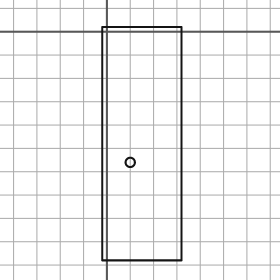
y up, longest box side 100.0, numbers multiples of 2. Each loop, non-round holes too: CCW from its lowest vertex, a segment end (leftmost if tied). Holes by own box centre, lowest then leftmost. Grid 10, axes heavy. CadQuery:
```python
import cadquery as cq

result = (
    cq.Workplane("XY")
    .moveTo(-2.0, -98.0)
    .lineTo(32.0, -98.0)
    .lineTo(32.0, 2.0)
    .lineTo(-2.0, 2.0)
    .close()
    .moveTo(10.0, -56.0)
    .circle(2.0)
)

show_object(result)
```